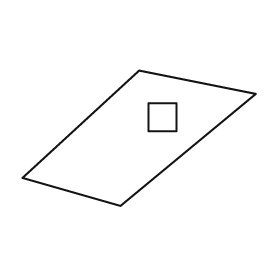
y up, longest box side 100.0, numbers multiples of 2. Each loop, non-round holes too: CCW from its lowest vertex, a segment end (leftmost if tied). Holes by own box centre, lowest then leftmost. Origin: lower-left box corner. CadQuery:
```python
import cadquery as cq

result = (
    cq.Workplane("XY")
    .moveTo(42.0, 0.0)
    .lineTo(100.0, 48.0)
    .lineTo(50.0, 58.0)
    .lineTo(0.0, 12.0)
    .close()
    .moveTo(54.0, 32.0)
    .lineTo(66.0, 32.0)
    .lineTo(66.0, 44.0)
    .lineTo(54.0, 44.0)
    .close()
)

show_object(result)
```